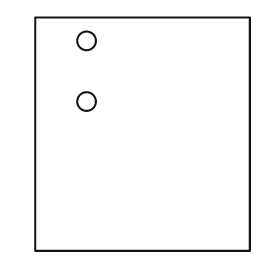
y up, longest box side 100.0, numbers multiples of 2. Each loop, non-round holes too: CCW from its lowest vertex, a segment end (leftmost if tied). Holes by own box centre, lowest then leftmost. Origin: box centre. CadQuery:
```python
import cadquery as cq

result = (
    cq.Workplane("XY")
    .moveTo(-46.0, -50.0)
    .lineTo(46.0, -50.0)
    .lineTo(46.0, 50.0)
    .lineTo(-46.0, 50.0)
    .close()
    .moveTo(-24.0, 14.0)
    .circle(4.0)
    .moveTo(-24.0, 40.0)
    .circle(4.0)
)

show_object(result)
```